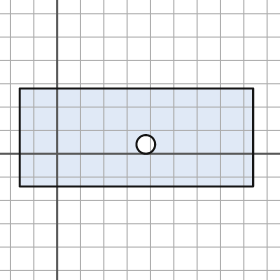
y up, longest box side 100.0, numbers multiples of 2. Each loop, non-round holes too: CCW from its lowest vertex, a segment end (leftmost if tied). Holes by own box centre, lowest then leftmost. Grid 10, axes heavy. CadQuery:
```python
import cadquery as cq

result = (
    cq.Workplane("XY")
    .moveTo(-16.0, -14.0)
    .lineTo(84.0, -14.0)
    .lineTo(84.0, 28.0)
    .lineTo(-16.0, 28.0)
    .close()
    .moveTo(38.0, 4.0)
    .circle(4.0)
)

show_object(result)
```